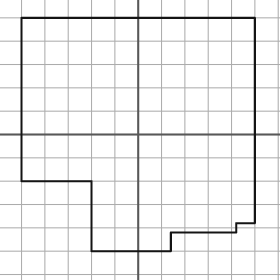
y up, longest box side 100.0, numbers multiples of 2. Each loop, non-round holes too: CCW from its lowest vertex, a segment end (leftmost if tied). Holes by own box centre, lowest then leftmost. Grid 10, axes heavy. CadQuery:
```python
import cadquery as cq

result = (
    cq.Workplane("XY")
    .moveTo(-20.0, -50.0)
    .lineTo(14.0, -50.0)
    .lineTo(14.0, -42.0)
    .lineTo(42.0, -42.0)
    .lineTo(42.0, -38.0)
    .lineTo(50.0, -38.0)
    .lineTo(50.0, 50.0)
    .lineTo(-50.0, 50.0)
    .lineTo(-50.0, -20.0)
    .lineTo(-20.0, -20.0)
    .close()
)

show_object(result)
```